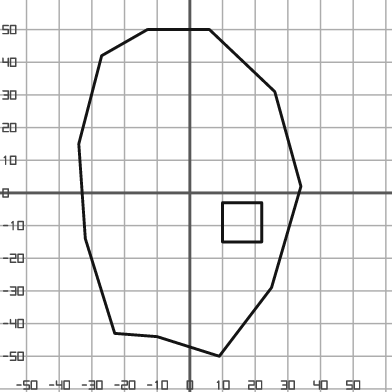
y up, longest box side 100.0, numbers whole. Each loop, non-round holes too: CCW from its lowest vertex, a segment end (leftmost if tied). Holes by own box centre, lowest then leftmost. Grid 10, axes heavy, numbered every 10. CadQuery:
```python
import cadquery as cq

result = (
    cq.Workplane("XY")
    .moveTo(9.0, -50.0)
    .lineTo(25.0, -29.0)
    .lineTo(34.0, 2.0)
    .lineTo(26.0, 31.0)
    .lineTo(6.0, 50.0)
    .lineTo(-13.0, 50.0)
    .lineTo(-27.0, 42.0)
    .lineTo(-34.0, 15.0)
    .lineTo(-32.0, -14.0)
    .lineTo(-23.0, -43.0)
    .lineTo(-10.0, -44.0)
    .close()
    .moveTo(10.0, -15.0)
    .lineTo(22.0, -15.0)
    .lineTo(22.0, -3.0)
    .lineTo(10.0, -3.0)
    .close()
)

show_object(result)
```